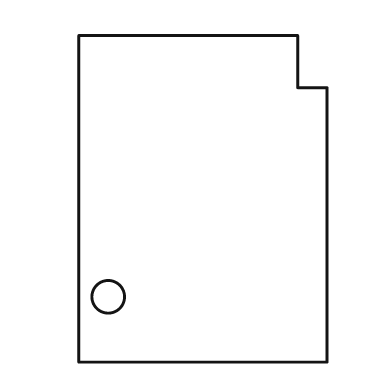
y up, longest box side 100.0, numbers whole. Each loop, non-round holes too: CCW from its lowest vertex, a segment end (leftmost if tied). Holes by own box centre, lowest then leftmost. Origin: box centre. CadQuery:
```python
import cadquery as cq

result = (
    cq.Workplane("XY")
    .moveTo(-38.0, -50.0)
    .lineTo(38.0, -50.0)
    .lineTo(38.0, 34.0)
    .lineTo(29.0, 34.0)
    .lineTo(29.0, 50.0)
    .lineTo(-38.0, 50.0)
    .close()
    .moveTo(-29.0, -30.0)
    .circle(5.0)
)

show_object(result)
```